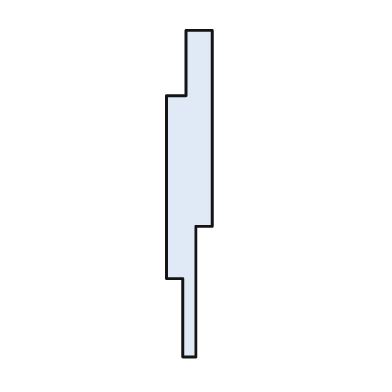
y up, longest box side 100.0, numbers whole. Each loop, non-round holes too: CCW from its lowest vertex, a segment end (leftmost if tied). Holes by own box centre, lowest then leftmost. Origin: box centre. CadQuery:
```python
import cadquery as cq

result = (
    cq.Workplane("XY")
    .moveTo(-2.0, -50.0)
    .lineTo(2.0, -50.0)
    .lineTo(2.0, -10.0)
    .lineTo(7.0, -10.0)
    .lineTo(7.0, 50.0)
    .lineTo(-1.0, 50.0)
    .lineTo(-1.0, 30.0)
    .lineTo(-7.0, 30.0)
    .lineTo(-7.0, -26.0)
    .lineTo(-2.0, -26.0)
    .close()
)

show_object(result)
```